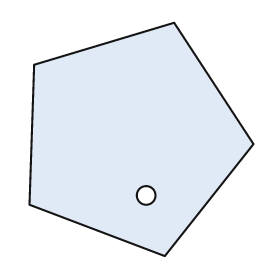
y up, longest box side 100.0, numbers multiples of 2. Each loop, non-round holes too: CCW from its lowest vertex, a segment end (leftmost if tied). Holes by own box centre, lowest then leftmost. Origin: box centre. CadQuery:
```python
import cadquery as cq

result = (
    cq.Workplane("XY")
    .moveTo(10.0, -50.0)
    .lineTo(48.0, -2.0)
    .lineTo(14.0, 50.0)
    .lineTo(-46.0, 32.0)
    .lineTo(-48.0, -28.0)
    .close()
    .moveTo(2.0, -24.0)
    .circle(4.0)
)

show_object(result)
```